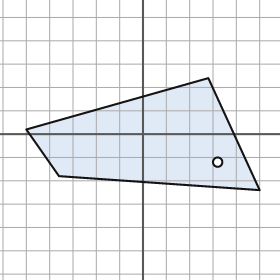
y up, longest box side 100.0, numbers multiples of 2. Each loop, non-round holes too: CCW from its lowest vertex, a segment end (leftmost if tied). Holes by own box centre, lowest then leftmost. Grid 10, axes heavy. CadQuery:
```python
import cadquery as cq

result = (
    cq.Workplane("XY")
    .moveTo(50.0, -24.0)
    .lineTo(28.0, 24.0)
    .lineTo(-50.0, 2.0)
    .lineTo(-36.0, -18.0)
    .close()
    .moveTo(32.0, -12.0)
    .circle(2.0)
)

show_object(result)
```